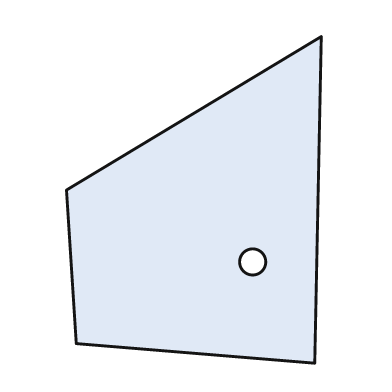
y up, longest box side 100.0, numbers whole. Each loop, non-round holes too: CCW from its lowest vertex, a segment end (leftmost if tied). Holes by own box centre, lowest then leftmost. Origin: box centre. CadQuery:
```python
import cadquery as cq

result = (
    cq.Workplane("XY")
    .moveTo(37.0, -50.0)
    .lineTo(39.0, 50.0)
    .lineTo(-39.0, 3.0)
    .lineTo(-36.0, -44.0)
    .close()
    .moveTo(18.0, -19.0)
    .circle(4.0)
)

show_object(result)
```